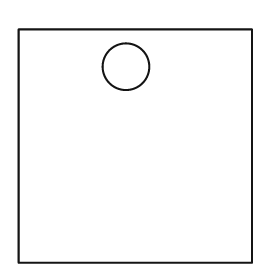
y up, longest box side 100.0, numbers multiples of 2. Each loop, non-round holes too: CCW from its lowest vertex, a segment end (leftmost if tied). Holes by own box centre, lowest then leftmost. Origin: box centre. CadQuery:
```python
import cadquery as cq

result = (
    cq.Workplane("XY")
    .moveTo(-50.0, -50.0)
    .lineTo(50.0, -50.0)
    .lineTo(50.0, 50.0)
    .lineTo(-50.0, 50.0)
    .close()
    .moveTo(-4.0, 34.0)
    .circle(10.0)
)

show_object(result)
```